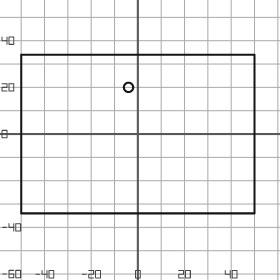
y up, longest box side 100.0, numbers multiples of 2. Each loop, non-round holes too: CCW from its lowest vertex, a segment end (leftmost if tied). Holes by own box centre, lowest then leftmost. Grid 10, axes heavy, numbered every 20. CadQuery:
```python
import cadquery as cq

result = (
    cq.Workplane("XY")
    .moveTo(-50.0, -34.0)
    .lineTo(50.0, -34.0)
    .lineTo(50.0, 34.0)
    .lineTo(-50.0, 34.0)
    .close()
    .moveTo(-4.0, 20.0)
    .circle(2.0)
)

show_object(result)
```